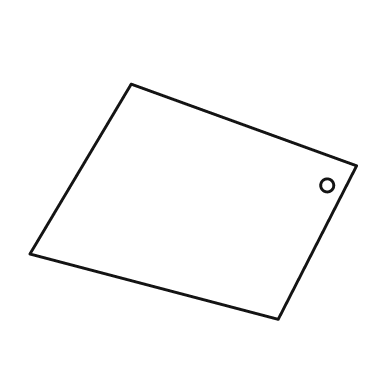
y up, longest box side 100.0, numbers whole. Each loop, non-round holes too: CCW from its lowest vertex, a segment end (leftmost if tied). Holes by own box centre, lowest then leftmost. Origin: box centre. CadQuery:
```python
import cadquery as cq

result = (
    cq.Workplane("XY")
    .moveTo(26.0, -36.0)
    .lineTo(50.0, 11.0)
    .lineTo(-19.0, 36.0)
    .lineTo(-50.0, -16.0)
    .close()
    .moveTo(41.0, 5.0)
    .circle(2.0)
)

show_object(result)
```